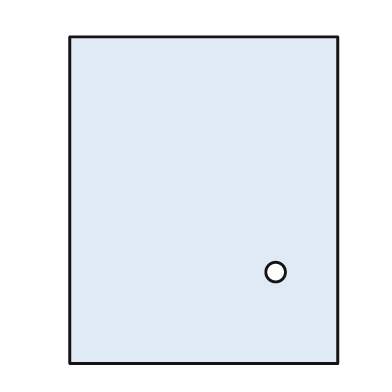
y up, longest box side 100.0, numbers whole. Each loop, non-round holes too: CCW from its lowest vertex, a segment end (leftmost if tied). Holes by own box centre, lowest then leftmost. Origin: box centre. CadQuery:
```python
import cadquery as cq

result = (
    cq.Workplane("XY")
    .moveTo(-41.0, -50.0)
    .lineTo(41.0, -50.0)
    .lineTo(41.0, 50.0)
    .lineTo(-41.0, 50.0)
    .close()
    .moveTo(22.0, -22.0)
    .circle(3.0)
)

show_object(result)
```